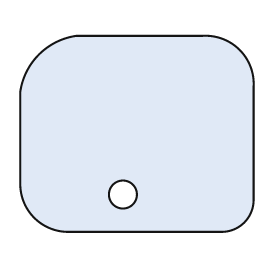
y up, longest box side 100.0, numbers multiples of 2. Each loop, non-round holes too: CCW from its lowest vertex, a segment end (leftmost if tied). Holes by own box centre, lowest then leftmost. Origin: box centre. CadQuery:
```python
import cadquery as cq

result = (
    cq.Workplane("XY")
    .moveTo(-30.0, -42.0)
    .lineTo(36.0, -42.0)
    .threePointArc((46.0, -38.0), (50.0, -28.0))
    .lineTo(50.0, 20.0)
    .threePointArc((44.0, 36.0), (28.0, 42.0))
    .lineTo(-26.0, 42.0)
    .threePointArc((-42.0, 34.0), (-50.0, 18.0))
    .lineTo(-50.0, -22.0)
    .threePointArc((-44.0, -36.0), (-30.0, -42.0))
    .close()
    .moveTo(-6.0, -26.0)
    .circle(6.0)
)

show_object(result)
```